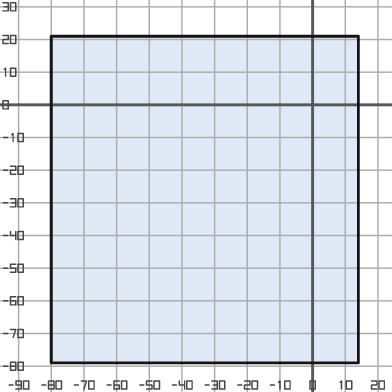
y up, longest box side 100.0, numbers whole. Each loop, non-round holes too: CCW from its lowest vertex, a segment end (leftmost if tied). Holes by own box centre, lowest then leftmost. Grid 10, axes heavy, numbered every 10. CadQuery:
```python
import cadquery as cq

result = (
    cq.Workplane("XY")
    .moveTo(-80.0, -79.0)
    .lineTo(14.0, -79.0)
    .lineTo(14.0, 21.0)
    .lineTo(-80.0, 21.0)
    .close()
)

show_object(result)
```